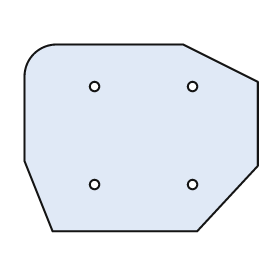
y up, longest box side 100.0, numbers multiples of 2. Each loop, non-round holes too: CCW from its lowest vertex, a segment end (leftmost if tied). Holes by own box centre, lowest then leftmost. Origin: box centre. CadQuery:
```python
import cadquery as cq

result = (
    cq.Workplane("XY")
    .moveTo(-38.0, -40.0)
    .lineTo(24.0, -40.0)
    .lineTo(50.0, -12.0)
    .lineTo(50.0, 24.0)
    .lineTo(18.0, 40.0)
    .lineTo(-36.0, 40.0)
    .threePointArc((-46.0, 36.0), (-50.0, 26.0))
    .lineTo(-50.0, -10.0)
    .close()
    .moveTo(-20.0, -20.0)
    .circle(2.0)
    .moveTo(22.0, -20.0)
    .circle(2.0)
    .moveTo(-20.0, 22.0)
    .circle(2.0)
    .moveTo(22.0, 22.0)
    .circle(2.0)
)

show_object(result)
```